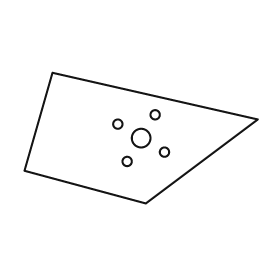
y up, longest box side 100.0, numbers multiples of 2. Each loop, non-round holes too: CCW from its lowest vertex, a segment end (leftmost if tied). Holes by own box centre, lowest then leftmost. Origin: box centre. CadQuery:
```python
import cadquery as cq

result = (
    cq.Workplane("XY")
    .moveTo(2.0, -28.0)
    .lineTo(50.0, 8.0)
    .lineTo(-38.0, 28.0)
    .lineTo(-50.0, -14.0)
    .close()
    .moveTo(-6.0, -10.0)
    .circle(2.0)
    .moveTo(10.0, -6.0)
    .circle(2.0)
    .moveTo(0.0, 0.0)
    .circle(4.0)
    .moveTo(-10.0, 6.0)
    .circle(2.0)
    .moveTo(6.0, 10.0)
    .circle(2.0)
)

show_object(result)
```